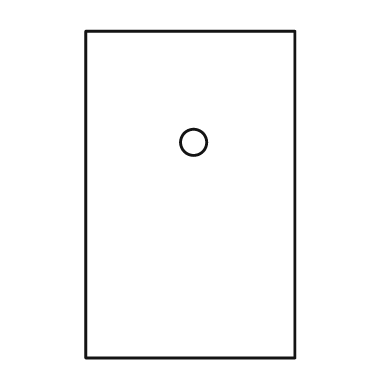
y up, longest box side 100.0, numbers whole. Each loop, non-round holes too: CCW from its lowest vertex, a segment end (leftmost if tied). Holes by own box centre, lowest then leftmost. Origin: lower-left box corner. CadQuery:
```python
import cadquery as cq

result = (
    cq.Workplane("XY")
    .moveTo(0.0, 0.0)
    .lineTo(64.0, 0.0)
    .lineTo(64.0, 100.0)
    .lineTo(0.0, 100.0)
    .close()
    .moveTo(33.0, 66.0)
    .circle(4.0)
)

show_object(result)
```